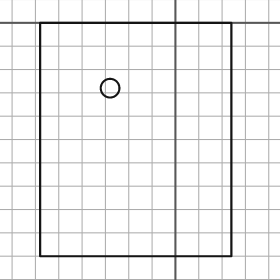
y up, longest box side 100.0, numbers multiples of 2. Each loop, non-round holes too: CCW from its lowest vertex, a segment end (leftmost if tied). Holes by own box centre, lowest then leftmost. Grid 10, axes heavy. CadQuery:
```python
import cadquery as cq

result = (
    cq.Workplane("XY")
    .moveTo(-58.0, -100.0)
    .lineTo(24.0, -100.0)
    .lineTo(24.0, 0.0)
    .lineTo(-58.0, 0.0)
    .close()
    .moveTo(-28.0, -28.0)
    .circle(4.0)
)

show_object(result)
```